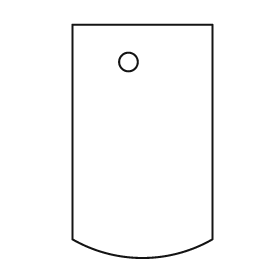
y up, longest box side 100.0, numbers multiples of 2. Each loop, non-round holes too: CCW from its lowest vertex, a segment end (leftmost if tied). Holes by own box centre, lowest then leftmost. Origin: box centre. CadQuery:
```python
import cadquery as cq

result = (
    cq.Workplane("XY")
    .moveTo(-30.0, -42.0)
    .threePointArc((0.0, -50.0), (30.0, -42.0))
    .lineTo(30.0, 50.0)
    .lineTo(-30.0, 50.0)
    .close()
    .moveTo(-6.0, 34.0)
    .circle(4.0)
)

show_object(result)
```